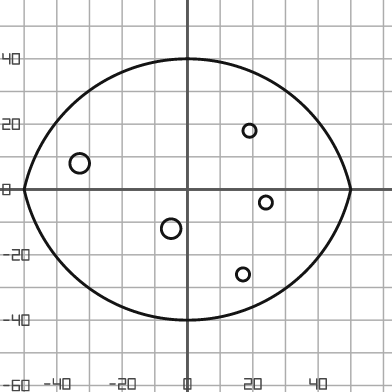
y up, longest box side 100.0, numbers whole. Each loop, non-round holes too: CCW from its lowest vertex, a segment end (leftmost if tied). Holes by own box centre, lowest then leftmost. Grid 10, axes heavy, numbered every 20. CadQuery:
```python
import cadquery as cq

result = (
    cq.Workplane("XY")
    .moveTo(-50.0, 0.0)
    .threePointArc((0.0, -40.0), (50.0, 0.0))
    .threePointArc((0.0, 40.0), (-50.0, 0.0))
    .close()
    .moveTo(17.0, -26.0)
    .circle(2.0)
    .moveTo(-5.0, -12.0)
    .circle(3.0)
    .moveTo(24.0, -4.0)
    .circle(2.0)
    .moveTo(-33.0, 8.0)
    .circle(3.0)
    .moveTo(19.0, 18.0)
    .circle(2.0)
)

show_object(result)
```